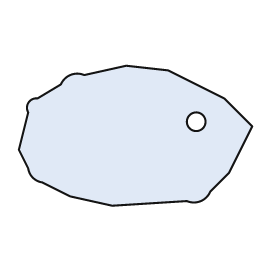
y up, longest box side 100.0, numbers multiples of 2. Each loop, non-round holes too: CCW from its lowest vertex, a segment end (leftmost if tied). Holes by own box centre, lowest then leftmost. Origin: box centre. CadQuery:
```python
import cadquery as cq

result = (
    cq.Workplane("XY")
    .moveTo(-10.0, -30.0)
    .lineTo(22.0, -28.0)
    .threePointArc((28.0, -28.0), (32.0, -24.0))
    .lineTo(40.0, -16.0)
    .lineTo(50.0, 4.0)
    .lineTo(38.0, 16.0)
    .lineTo(14.0, 28.0)
    .lineTo(-4.0, 30.0)
    .lineTo(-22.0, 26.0)
    .threePointArc((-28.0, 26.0), (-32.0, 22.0))
    .lineTo(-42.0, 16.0)
    .threePointArc((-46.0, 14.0), (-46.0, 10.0))
    .lineTo(-50.0, -6.0)
    .lineTo(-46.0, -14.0)
    .threePointArc((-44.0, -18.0), (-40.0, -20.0))
    .lineTo(-28.0, -26.0)
    .close()
    .moveTo(26.0, 6.0)
    .circle(4.0)
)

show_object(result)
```